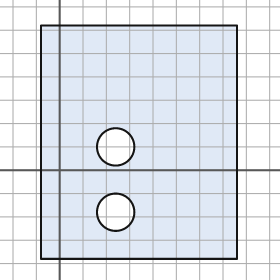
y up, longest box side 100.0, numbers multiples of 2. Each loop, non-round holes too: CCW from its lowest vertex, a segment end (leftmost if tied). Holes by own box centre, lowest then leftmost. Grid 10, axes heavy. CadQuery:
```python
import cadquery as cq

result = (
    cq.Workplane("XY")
    .moveTo(-8.0, -38.0)
    .lineTo(76.0, -38.0)
    .lineTo(76.0, 62.0)
    .lineTo(-8.0, 62.0)
    .close()
    .moveTo(24.0, -18.0)
    .circle(8.0)
    .moveTo(24.0, 10.0)
    .circle(8.0)
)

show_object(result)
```